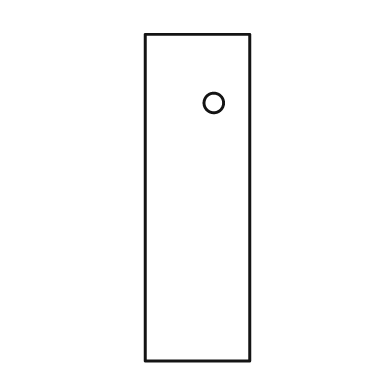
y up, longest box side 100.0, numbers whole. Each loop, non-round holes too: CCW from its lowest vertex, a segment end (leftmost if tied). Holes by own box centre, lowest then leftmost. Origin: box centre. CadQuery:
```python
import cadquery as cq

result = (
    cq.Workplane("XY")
    .moveTo(-16.0, -50.0)
    .lineTo(16.0, -50.0)
    .lineTo(16.0, 50.0)
    .lineTo(-16.0, 50.0)
    .close()
    .moveTo(5.0, 29.0)
    .circle(3.0)
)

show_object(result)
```